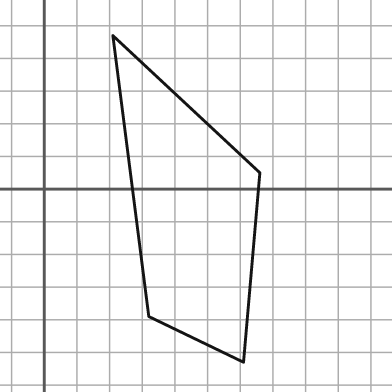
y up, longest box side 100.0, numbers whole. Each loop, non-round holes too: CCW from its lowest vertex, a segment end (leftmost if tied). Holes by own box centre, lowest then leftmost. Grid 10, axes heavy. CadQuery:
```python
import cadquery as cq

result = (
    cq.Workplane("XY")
    .moveTo(61.0, -53.0)
    .lineTo(66.0, 5.0)
    .lineTo(21.0, 47.0)
    .lineTo(32.0, -39.0)
    .close()
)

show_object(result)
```